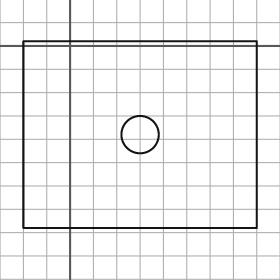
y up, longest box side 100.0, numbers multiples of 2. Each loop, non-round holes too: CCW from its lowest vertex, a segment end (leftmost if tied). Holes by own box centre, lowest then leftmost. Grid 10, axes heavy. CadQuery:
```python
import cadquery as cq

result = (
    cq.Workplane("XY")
    .moveTo(-20.0, -78.0)
    .lineTo(80.0, -78.0)
    .lineTo(80.0, 2.0)
    .lineTo(-20.0, 2.0)
    .close()
    .moveTo(30.0, -38.0)
    .circle(8.0)
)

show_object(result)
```